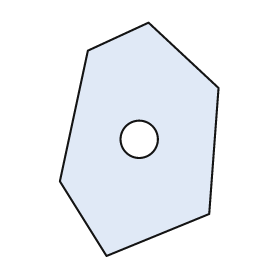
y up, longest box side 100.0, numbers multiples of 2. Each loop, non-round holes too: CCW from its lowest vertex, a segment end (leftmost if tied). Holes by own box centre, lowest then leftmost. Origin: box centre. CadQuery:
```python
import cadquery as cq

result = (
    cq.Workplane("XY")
    .moveTo(-14.0, -50.0)
    .lineTo(30.0, -32.0)
    .lineTo(34.0, 22.0)
    .lineTo(4.0, 50.0)
    .lineTo(-22.0, 38.0)
    .lineTo(-34.0, -18.0)
    .close()
    .moveTo(0.0, 0.0)
    .circle(8.0)
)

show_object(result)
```